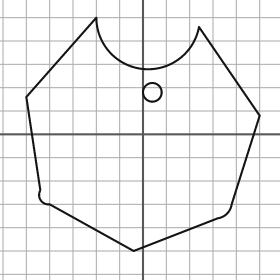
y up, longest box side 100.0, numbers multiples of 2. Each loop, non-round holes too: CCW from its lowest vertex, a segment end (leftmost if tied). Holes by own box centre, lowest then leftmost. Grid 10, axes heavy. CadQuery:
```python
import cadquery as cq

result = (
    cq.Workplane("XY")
    .moveTo(-4.0, -50.0)
    .lineTo(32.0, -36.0)
    .threePointArc((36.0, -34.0), (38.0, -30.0))
    .lineTo(50.0, 8.0)
    .lineTo(24.0, 46.0)
    .threePointArc((0.0, 28.0), (-20.0, 50.0))
    .lineTo(-50.0, 16.0)
    .lineTo(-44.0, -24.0)
    .threePointArc((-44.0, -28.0), (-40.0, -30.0))
    .close()
    .moveTo(4.0, 18.0)
    .circle(4.0)
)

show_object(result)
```